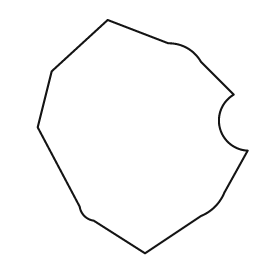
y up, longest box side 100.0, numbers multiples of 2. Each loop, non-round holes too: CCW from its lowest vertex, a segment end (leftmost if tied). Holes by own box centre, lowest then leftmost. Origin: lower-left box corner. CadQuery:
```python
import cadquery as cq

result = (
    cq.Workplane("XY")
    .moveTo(46.0, 0.0)
    .lineTo(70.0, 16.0)
    .threePointArc((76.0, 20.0), (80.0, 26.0))
    .lineTo(90.0, 44.0)
    .threePointArc((78.0, 54.0), (84.0, 68.0))
    .lineTo(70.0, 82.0)
    .threePointArc((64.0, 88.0), (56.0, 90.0))
    .lineTo(30.0, 100.0)
    .lineTo(6.0, 78.0)
    .lineTo(0.0, 54.0)
    .lineTo(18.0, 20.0)
    .threePointArc((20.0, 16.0), (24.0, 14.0))
    .close()
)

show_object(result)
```